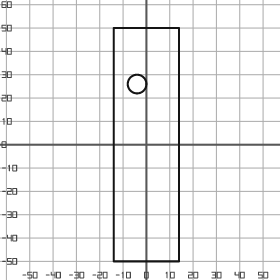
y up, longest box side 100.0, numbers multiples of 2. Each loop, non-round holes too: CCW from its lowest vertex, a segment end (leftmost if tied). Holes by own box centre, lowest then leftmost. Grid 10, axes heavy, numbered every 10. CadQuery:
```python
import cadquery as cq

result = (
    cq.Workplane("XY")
    .moveTo(-14.0, -50.0)
    .lineTo(14.0, -50.0)
    .lineTo(14.0, 50.0)
    .lineTo(-14.0, 50.0)
    .close()
    .moveTo(-4.0, 26.0)
    .circle(4.0)
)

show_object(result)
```